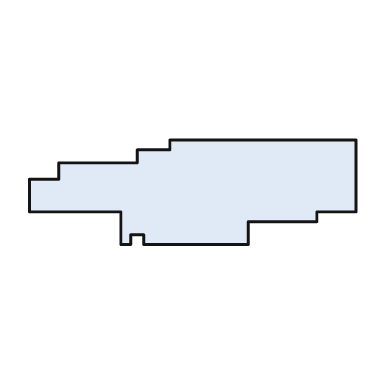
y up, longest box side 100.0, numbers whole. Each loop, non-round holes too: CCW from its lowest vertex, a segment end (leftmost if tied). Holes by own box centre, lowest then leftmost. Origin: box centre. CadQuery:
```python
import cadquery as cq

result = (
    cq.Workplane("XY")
    .moveTo(-22.0, -16.0)
    .lineTo(-19.0, -16.0)
    .lineTo(-19.0, -13.0)
    .lineTo(-15.0, -13.0)
    .lineTo(-15.0, -16.0)
    .lineTo(17.0, -16.0)
    .lineTo(17.0, -9.0)
    .lineTo(38.0, -9.0)
    .lineTo(38.0, -6.0)
    .lineTo(50.0, -6.0)
    .lineTo(50.0, 16.0)
    .lineTo(-7.0, 16.0)
    .lineTo(-7.0, 13.0)
    .lineTo(-17.0, 13.0)
    .lineTo(-17.0, 9.0)
    .lineTo(-41.0, 9.0)
    .lineTo(-41.0, 4.0)
    .lineTo(-50.0, 4.0)
    .lineTo(-50.0, -6.0)
    .lineTo(-22.0, -6.0)
    .close()
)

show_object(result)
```